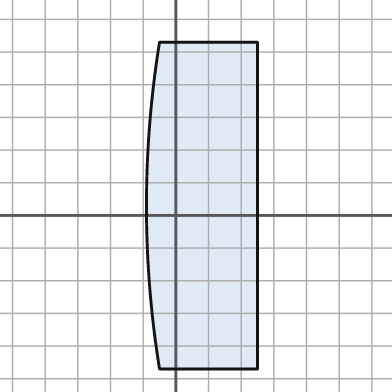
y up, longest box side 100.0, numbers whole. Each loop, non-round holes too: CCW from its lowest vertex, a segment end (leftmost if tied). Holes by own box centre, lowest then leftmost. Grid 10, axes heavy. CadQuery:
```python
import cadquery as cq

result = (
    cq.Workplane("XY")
    .moveTo(-5.0, -47.0)
    .lineTo(25.0, -47.0)
    .lineTo(25.0, 53.0)
    .lineTo(-5.0, 53.0)
    .threePointArc((-9.0, 3.0), (-5.0, -47.0))
    .close()
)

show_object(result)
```